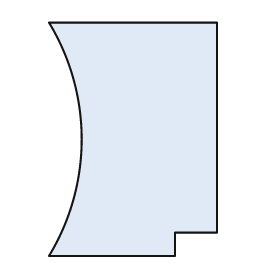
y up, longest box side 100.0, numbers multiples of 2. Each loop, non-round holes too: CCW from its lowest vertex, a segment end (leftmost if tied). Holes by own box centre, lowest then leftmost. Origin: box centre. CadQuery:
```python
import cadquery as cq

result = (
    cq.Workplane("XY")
    .moveTo(-36.0, -50.0)
    .lineTo(18.0, -50.0)
    .lineTo(18.0, -40.0)
    .lineTo(36.0, -40.0)
    .lineTo(36.0, 50.0)
    .lineTo(-36.0, 50.0)
    .threePointArc((-22.0, 0.0), (-36.0, -50.0))
    .close()
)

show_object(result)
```